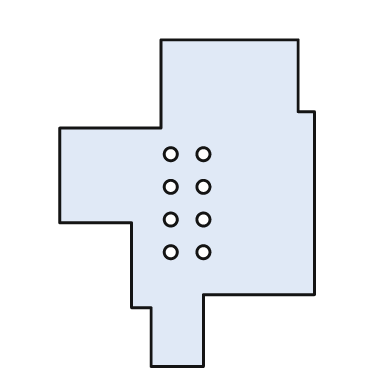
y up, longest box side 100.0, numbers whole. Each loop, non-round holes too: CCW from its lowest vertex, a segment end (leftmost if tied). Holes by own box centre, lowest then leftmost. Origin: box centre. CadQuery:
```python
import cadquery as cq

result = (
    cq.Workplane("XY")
    .moveTo(-11.0, -50.0)
    .lineTo(5.0, -50.0)
    .lineTo(5.0, -28.0)
    .lineTo(39.0, -28.0)
    .lineTo(39.0, 28.0)
    .lineTo(34.0, 28.0)
    .lineTo(34.0, 50.0)
    .lineTo(-8.0, 50.0)
    .lineTo(-8.0, 23.0)
    .lineTo(-39.0, 23.0)
    .lineTo(-39.0, -6.0)
    .lineTo(-17.0, -6.0)
    .lineTo(-17.0, -32.0)
    .lineTo(-11.0, -32.0)
    .close()
    .moveTo(-5.0, -15.0)
    .circle(2.0)
    .moveTo(5.0, -15.0)
    .circle(2.0)
    .moveTo(-5.0, -5.0)
    .circle(2.0)
    .moveTo(5.0, -5.0)
    .circle(2.0)
    .moveTo(-5.0, 5.0)
    .circle(2.0)
    .moveTo(5.0, 5.0)
    .circle(2.0)
    .moveTo(-5.0, 15.0)
    .circle(2.0)
    .moveTo(5.0, 15.0)
    .circle(2.0)
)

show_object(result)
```